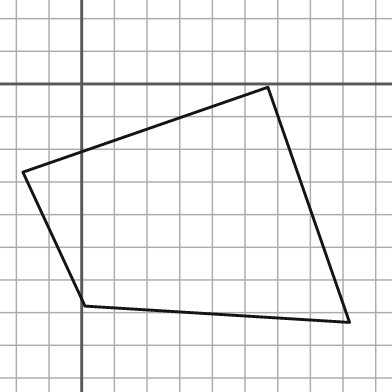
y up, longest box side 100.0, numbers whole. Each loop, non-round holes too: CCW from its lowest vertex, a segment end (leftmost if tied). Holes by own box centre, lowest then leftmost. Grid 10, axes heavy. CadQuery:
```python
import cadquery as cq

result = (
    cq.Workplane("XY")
    .moveTo(82.0, -73.0)
    .lineTo(57.0, -1.0)
    .lineTo(-18.0, -27.0)
    .lineTo(1.0, -68.0)
    .close()
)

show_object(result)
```